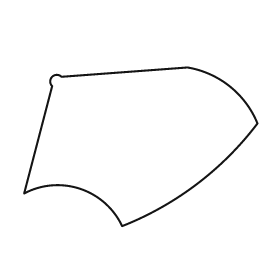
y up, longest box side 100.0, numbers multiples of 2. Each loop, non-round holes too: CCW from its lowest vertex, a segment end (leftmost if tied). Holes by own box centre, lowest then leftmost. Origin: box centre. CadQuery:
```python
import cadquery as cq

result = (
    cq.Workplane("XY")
    .moveTo(-8.0, -34.0)
    .threePointArc((24.0, -16.0), (50.0, 10.0))
    .threePointArc((38.0, 26.0), (20.0, 34.0))
    .lineTo(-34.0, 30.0)
    .threePointArc((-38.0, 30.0), (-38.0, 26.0))
    .lineTo(-50.0, -20.0)
    .threePointArc((-26.0, -18.0), (-8.0, -34.0))
    .close()
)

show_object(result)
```